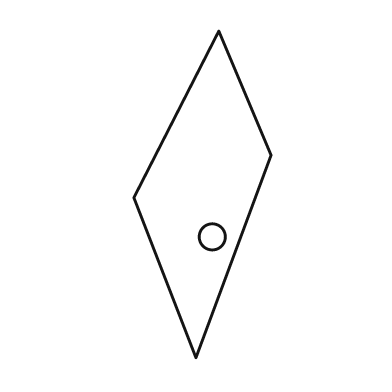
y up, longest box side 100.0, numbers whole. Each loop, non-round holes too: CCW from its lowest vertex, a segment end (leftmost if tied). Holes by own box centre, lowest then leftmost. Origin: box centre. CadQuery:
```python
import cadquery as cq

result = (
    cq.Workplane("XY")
    .moveTo(-2.0, -50.0)
    .lineTo(21.0, 12.0)
    .lineTo(5.0, 50.0)
    .lineTo(-21.0, -1.0)
    .close()
    .moveTo(3.0, -13.0)
    .circle(4.0)
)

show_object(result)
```